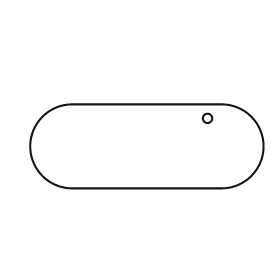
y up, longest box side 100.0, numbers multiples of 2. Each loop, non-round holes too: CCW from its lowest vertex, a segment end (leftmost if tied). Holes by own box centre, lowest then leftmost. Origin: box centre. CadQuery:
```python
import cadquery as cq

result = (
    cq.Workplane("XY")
    .moveTo(-32.0, -18.0)
    .lineTo(32.0, -18.0)
    .threePointArc((50.0, 0.0), (32.0, 18.0))
    .lineTo(-32.0, 18.0)
    .threePointArc((-50.0, 0.0), (-32.0, -18.0))
    .close()
    .moveTo(26.0, 12.0)
    .circle(2.0)
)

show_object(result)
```